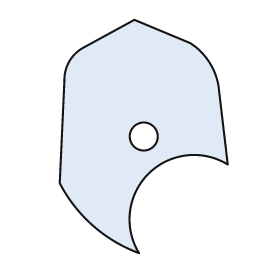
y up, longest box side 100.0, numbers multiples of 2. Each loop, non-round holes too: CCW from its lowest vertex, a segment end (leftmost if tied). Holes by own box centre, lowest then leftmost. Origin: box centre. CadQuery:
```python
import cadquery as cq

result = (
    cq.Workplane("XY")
    .moveTo(-2.0, -50.0)
    .threePointArc((2.0, -16.0), (36.0, -12.0))
    .lineTo(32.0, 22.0)
    .threePointArc((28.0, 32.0), (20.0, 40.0))
    .lineTo(-4.0, 50.0)
    .lineTo(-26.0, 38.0)
    .threePointArc((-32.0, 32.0), (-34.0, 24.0))
    .lineTo(-36.0, -20.0)
    .threePointArc((-22.0, -38.0), (-2.0, -50.0))
    .close()
    .moveTo(0.0, 0.0)
    .circle(6.0)
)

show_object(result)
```